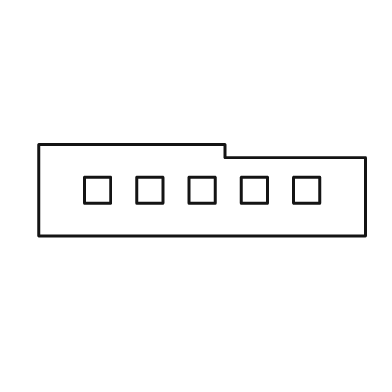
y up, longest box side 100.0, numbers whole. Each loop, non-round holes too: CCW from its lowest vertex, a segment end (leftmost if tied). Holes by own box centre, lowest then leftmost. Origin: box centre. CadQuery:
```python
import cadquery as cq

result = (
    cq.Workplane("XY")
    .moveTo(-50.0, -14.0)
    .lineTo(50.0, -14.0)
    .lineTo(50.0, 10.0)
    .lineTo(7.0, 10.0)
    .lineTo(7.0, 14.0)
    .lineTo(-50.0, 14.0)
    .close()
    .moveTo(-36.0, -4.0)
    .lineTo(-28.0, -4.0)
    .lineTo(-28.0, 4.0)
    .lineTo(-36.0, 4.0)
    .close()
    .moveTo(-20.0, -4.0)
    .lineTo(-12.0, -4.0)
    .lineTo(-12.0, 4.0)
    .lineTo(-20.0, 4.0)
    .close()
    .moveTo(-4.0, -4.0)
    .lineTo(4.0, -4.0)
    .lineTo(4.0, 4.0)
    .lineTo(-4.0, 4.0)
    .close()
    .moveTo(12.0, -4.0)
    .lineTo(20.0, -4.0)
    .lineTo(20.0, 4.0)
    .lineTo(12.0, 4.0)
    .close()
    .moveTo(28.0, -4.0)
    .lineTo(36.0, -4.0)
    .lineTo(36.0, 4.0)
    .lineTo(28.0, 4.0)
    .close()
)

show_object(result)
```